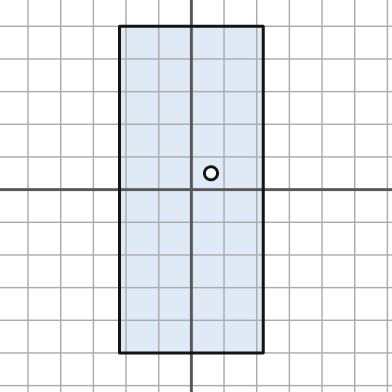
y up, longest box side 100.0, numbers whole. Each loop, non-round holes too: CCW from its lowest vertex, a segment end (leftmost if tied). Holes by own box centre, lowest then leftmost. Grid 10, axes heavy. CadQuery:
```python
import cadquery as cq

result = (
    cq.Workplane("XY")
    .moveTo(-22.0, -50.0)
    .lineTo(22.0, -50.0)
    .lineTo(22.0, 50.0)
    .lineTo(-22.0, 50.0)
    .close()
    .moveTo(6.0, 5.0)
    .circle(2.0)
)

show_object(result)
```